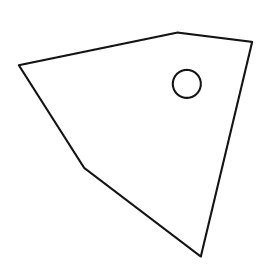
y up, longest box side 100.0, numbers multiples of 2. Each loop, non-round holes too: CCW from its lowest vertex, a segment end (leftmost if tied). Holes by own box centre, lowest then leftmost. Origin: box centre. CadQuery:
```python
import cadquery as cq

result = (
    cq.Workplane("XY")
    .moveTo(28.0, -48.0)
    .lineTo(50.0, 44.0)
    .lineTo(18.0, 48.0)
    .lineTo(-50.0, 34.0)
    .lineTo(-22.0, -10.0)
    .close()
    .moveTo(22.0, 26.0)
    .circle(6.0)
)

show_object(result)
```